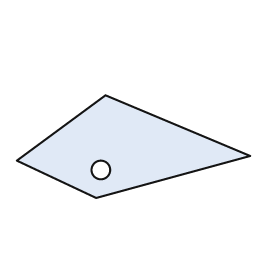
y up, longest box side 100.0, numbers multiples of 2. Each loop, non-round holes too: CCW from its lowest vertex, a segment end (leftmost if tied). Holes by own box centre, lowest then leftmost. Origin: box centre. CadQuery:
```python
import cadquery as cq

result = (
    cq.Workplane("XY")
    .moveTo(-16.0, -22.0)
    .lineTo(50.0, -4.0)
    .lineTo(-12.0, 22.0)
    .lineTo(-50.0, -6.0)
    .close()
    .moveTo(-14.0, -10.0)
    .circle(4.0)
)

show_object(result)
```